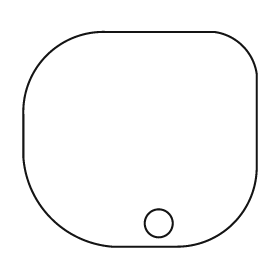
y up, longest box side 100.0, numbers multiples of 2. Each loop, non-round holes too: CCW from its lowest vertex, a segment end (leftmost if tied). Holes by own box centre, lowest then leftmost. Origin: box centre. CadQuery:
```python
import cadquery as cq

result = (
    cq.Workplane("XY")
    .moveTo(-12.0, -46.0)
    .lineTo(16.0, -46.0)
    .threePointArc((40.0, -36.0), (50.0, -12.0))
    .lineTo(50.0, 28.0)
    .threePointArc((44.0, 40.0), (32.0, 46.0))
    .lineTo(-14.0, 46.0)
    .threePointArc((-40.0, 36.0), (-50.0, 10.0))
    .lineTo(-50.0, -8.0)
    .threePointArc((-38.0, -34.0), (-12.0, -46.0))
    .close()
    .moveTo(8.0, -36.0)
    .circle(6.0)
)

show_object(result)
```